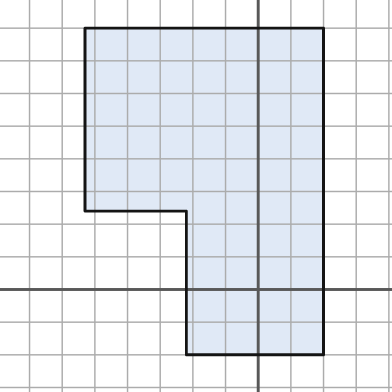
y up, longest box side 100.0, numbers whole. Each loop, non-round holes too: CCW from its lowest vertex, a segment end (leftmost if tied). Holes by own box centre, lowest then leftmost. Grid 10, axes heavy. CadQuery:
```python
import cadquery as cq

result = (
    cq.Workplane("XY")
    .moveTo(-22.0, -20.0)
    .lineTo(20.0, -20.0)
    .lineTo(20.0, 80.0)
    .lineTo(-53.0, 80.0)
    .lineTo(-53.0, 24.0)
    .lineTo(-22.0, 24.0)
    .close()
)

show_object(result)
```